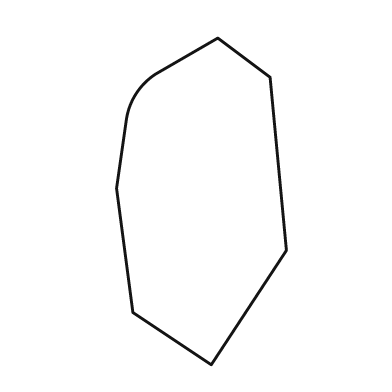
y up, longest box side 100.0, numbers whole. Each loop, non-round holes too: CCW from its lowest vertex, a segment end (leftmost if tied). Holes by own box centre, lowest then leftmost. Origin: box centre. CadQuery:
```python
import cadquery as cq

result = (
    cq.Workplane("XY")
    .moveTo(3.0, -50.0)
    .lineTo(26.0, -15.0)
    .lineTo(21.0, 38.0)
    .lineTo(5.0, 50.0)
    .lineTo(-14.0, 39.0)
    .threePointArc((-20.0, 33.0), (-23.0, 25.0))
    .lineTo(-26.0, 4.0)
    .lineTo(-21.0, -34.0)
    .close()
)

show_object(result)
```